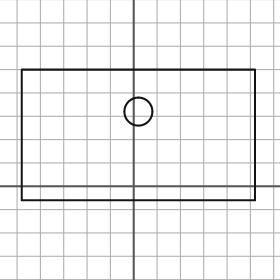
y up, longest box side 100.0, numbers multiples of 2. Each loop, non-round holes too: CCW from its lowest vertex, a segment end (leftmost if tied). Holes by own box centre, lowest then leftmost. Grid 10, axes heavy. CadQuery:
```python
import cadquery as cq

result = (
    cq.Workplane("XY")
    .moveTo(-48.0, -6.0)
    .lineTo(52.0, -6.0)
    .lineTo(52.0, 50.0)
    .lineTo(-48.0, 50.0)
    .close()
    .moveTo(2.0, 32.0)
    .circle(6.0)
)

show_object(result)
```